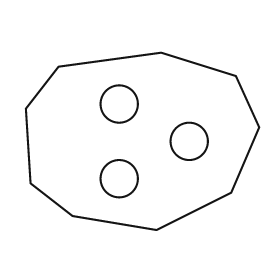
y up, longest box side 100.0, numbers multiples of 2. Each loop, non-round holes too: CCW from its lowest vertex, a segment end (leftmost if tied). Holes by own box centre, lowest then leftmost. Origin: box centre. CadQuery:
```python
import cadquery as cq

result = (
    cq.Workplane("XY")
    .moveTo(6.0, -38.0)
    .lineTo(38.0, -22.0)
    .lineTo(50.0, 6.0)
    .lineTo(40.0, 28.0)
    .lineTo(8.0, 38.0)
    .lineTo(-36.0, 32.0)
    .lineTo(-50.0, 14.0)
    .lineTo(-48.0, -18.0)
    .lineTo(-30.0, -32.0)
    .close()
    .moveTo(-10.0, -16.0)
    .circle(8.0)
    .moveTo(20.0, 0.0)
    .circle(8.0)
    .moveTo(-10.0, 16.0)
    .circle(8.0)
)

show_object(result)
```